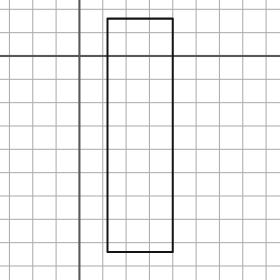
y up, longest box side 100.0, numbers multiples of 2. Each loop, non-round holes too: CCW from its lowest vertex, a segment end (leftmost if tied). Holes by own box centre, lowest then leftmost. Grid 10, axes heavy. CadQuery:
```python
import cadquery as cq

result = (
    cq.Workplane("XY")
    .moveTo(12.0, -84.0)
    .lineTo(40.0, -84.0)
    .lineTo(40.0, 16.0)
    .lineTo(12.0, 16.0)
    .close()
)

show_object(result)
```